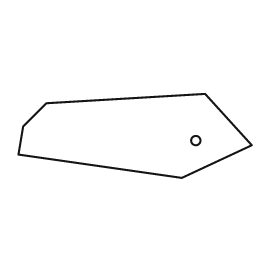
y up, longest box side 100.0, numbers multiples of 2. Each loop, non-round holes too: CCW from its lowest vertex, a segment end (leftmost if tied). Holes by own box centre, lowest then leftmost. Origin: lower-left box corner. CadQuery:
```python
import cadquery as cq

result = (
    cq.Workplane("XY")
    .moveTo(70.0, 0.0)
    .lineTo(100.0, 14.0)
    .lineTo(80.0, 36.0)
    .lineTo(12.0, 32.0)
    .lineTo(2.0, 22.0)
    .lineTo(0.0, 10.0)
    .close()
    .moveTo(76.0, 16.0)
    .circle(2.0)
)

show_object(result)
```